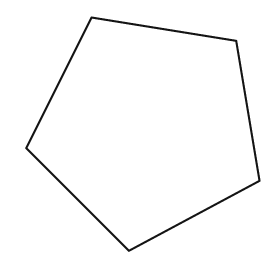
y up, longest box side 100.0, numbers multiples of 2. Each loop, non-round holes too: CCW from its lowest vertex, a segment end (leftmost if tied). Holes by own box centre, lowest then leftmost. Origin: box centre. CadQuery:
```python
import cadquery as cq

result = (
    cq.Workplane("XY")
    .moveTo(-6.0, -50.0)
    .lineTo(50.0, -20.0)
    .lineTo(40.0, 40.0)
    .lineTo(-22.0, 50.0)
    .lineTo(-50.0, -6.0)
    .close()
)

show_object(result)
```